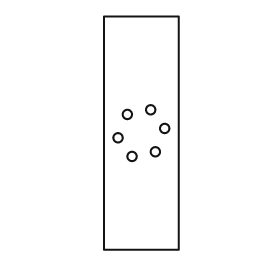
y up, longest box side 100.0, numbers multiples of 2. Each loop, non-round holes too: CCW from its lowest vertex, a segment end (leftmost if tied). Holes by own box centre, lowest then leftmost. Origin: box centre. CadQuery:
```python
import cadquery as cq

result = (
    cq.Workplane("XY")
    .moveTo(-16.0, -50.0)
    .lineTo(16.0, -50.0)
    .lineTo(16.0, 50.0)
    .lineTo(-16.0, 50.0)
    .close()
    .moveTo(-4.0, -10.0)
    .circle(2.0)
    .moveTo(6.0, -8.0)
    .circle(2.0)
    .moveTo(-10.0, -2.0)
    .circle(2.0)
    .moveTo(10.0, 2.0)
    .circle(2.0)
    .moveTo(-6.0, 8.0)
    .circle(2.0)
    .moveTo(4.0, 10.0)
    .circle(2.0)
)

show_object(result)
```